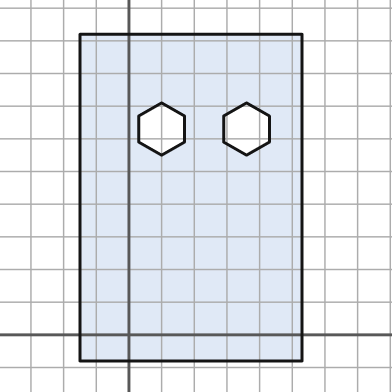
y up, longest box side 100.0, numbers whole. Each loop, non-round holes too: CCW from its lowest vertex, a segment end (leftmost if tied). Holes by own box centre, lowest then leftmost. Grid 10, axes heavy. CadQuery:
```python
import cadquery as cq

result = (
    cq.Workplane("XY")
    .moveTo(-15.0, -8.0)
    .lineTo(53.0, -8.0)
    .lineTo(53.0, 92.0)
    .lineTo(-15.0, 92.0)
    .close()
    .moveTo(10.0, 55.0)
    .lineTo(17.0, 59.0)
    .lineTo(17.0, 67.0)
    .lineTo(10.0, 71.0)
    .lineTo(3.0, 67.0)
    .lineTo(3.0, 59.0)
    .close()
    .moveTo(36.0, 55.0)
    .lineTo(43.0, 59.0)
    .lineTo(43.0, 67.0)
    .lineTo(36.0, 71.0)
    .lineTo(29.0, 67.0)
    .lineTo(29.0, 59.0)
    .close()
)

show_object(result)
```